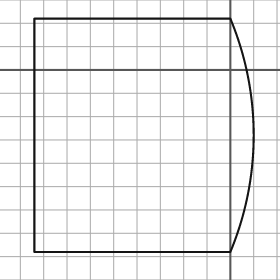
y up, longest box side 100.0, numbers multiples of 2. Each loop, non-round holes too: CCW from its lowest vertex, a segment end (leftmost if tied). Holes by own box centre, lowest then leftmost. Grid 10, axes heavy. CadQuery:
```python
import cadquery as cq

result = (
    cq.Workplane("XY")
    .moveTo(-84.0, -78.0)
    .lineTo(0.0, -78.0)
    .threePointArc((10.0, -28.0), (0.0, 22.0))
    .lineTo(-84.0, 22.0)
    .close()
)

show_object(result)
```